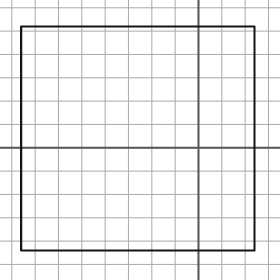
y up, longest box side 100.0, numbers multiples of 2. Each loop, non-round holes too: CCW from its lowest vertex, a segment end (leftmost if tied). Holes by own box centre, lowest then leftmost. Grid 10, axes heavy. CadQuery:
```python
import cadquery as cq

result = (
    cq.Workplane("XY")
    .moveTo(-76.0, -44.0)
    .lineTo(24.0, -44.0)
    .lineTo(24.0, 52.0)
    .lineTo(-76.0, 52.0)
    .close()
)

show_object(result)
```